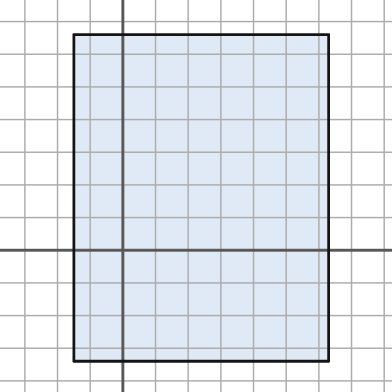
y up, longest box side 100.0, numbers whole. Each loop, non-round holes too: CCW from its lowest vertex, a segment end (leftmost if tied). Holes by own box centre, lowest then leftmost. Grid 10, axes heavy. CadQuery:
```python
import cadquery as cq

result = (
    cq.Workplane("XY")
    .moveTo(-15.0, -34.0)
    .lineTo(63.0, -34.0)
    .lineTo(63.0, 66.0)
    .lineTo(-15.0, 66.0)
    .close()
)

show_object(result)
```